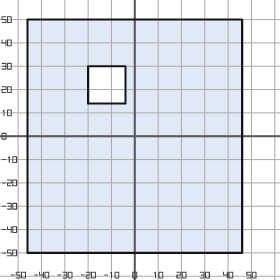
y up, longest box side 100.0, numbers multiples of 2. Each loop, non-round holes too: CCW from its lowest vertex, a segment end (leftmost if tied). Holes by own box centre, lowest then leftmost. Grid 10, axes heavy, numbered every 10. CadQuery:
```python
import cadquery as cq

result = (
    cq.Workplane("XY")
    .moveTo(-46.0, -50.0)
    .lineTo(46.0, -50.0)
    .lineTo(46.0, 50.0)
    .lineTo(-46.0, 50.0)
    .close()
    .moveTo(-20.0, 14.0)
    .lineTo(-4.0, 14.0)
    .lineTo(-4.0, 30.0)
    .lineTo(-20.0, 30.0)
    .close()
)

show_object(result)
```